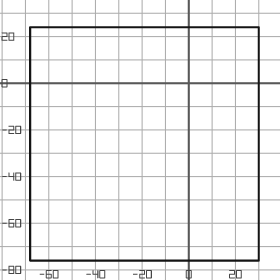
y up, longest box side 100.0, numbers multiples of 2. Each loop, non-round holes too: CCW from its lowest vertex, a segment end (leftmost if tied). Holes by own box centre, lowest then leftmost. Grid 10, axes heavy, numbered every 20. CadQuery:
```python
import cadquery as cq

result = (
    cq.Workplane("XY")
    .moveTo(-68.0, -76.0)
    .lineTo(30.0, -76.0)
    .lineTo(30.0, 24.0)
    .lineTo(-68.0, 24.0)
    .close()
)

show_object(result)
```